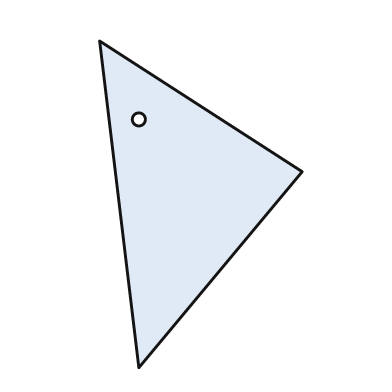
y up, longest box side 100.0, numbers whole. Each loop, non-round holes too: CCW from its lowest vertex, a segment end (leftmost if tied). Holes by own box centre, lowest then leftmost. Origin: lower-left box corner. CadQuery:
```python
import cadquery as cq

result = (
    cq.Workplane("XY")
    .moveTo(12.0, 0.0)
    .lineTo(62.0, 60.0)
    .lineTo(0.0, 100.0)
    .close()
    .moveTo(12.0, 76.0)
    .circle(2.0)
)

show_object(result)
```